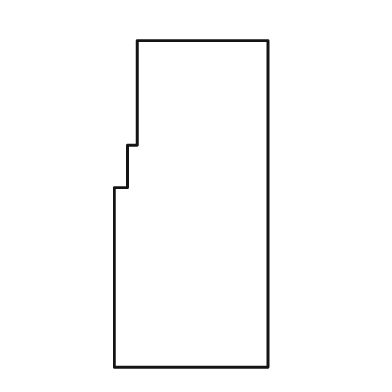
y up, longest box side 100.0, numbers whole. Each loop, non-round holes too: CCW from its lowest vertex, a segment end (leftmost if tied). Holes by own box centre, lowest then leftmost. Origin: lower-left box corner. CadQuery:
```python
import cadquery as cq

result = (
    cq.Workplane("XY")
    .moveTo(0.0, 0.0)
    .lineTo(47.0, 0.0)
    .lineTo(47.0, 100.0)
    .lineTo(7.0, 100.0)
    .lineTo(7.0, 68.0)
    .lineTo(4.0, 68.0)
    .lineTo(4.0, 55.0)
    .lineTo(0.0, 55.0)
    .close()
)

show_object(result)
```